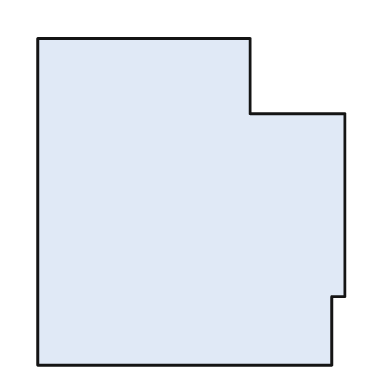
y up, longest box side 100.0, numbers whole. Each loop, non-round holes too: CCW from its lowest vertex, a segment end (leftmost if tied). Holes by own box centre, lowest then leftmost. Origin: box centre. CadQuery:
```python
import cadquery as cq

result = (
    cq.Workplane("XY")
    .moveTo(-47.0, -50.0)
    .lineTo(43.0, -50.0)
    .lineTo(43.0, -29.0)
    .lineTo(47.0, -29.0)
    .lineTo(47.0, 27.0)
    .lineTo(18.0, 27.0)
    .lineTo(18.0, 50.0)
    .lineTo(-47.0, 50.0)
    .close()
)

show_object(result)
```